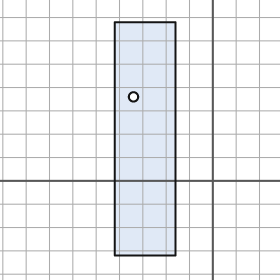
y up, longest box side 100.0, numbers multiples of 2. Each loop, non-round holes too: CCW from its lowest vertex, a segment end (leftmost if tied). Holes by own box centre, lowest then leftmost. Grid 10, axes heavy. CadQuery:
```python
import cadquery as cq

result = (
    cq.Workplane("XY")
    .moveTo(-42.0, -32.0)
    .lineTo(-16.0, -32.0)
    .lineTo(-16.0, 68.0)
    .lineTo(-42.0, 68.0)
    .close()
    .moveTo(-34.0, 36.0)
    .circle(2.0)
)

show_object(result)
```